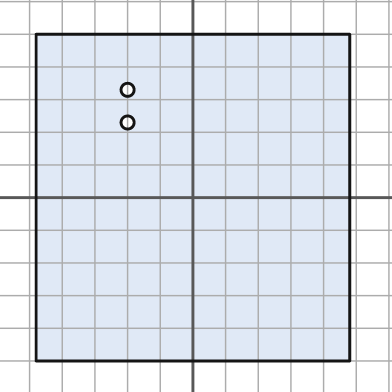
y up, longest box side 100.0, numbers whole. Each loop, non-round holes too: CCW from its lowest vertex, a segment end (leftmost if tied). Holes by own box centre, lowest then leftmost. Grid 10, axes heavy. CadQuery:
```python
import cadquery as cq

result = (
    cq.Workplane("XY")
    .moveTo(-48.0, -50.0)
    .lineTo(48.0, -50.0)
    .lineTo(48.0, 50.0)
    .lineTo(-48.0, 50.0)
    .close()
    .moveTo(-20.0, 23.0)
    .circle(2.0)
    .moveTo(-20.0, 33.0)
    .circle(2.0)
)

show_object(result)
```